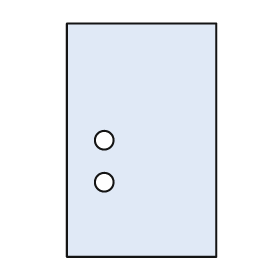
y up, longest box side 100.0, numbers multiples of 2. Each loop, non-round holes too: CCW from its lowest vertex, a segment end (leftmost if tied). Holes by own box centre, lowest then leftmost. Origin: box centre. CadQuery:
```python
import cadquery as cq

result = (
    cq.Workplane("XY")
    .moveTo(-32.0, -50.0)
    .lineTo(32.0, -50.0)
    .lineTo(32.0, 50.0)
    .lineTo(-32.0, 50.0)
    .close()
    .moveTo(-16.0, -18.0)
    .circle(4.0)
    .moveTo(-16.0, 0.0)
    .circle(4.0)
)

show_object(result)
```